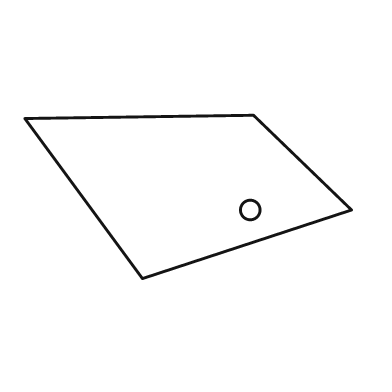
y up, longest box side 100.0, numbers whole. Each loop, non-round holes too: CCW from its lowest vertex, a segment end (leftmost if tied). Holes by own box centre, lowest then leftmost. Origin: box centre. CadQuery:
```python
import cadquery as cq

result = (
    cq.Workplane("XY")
    .moveTo(-14.0, -25.0)
    .lineTo(50.0, -4.0)
    .lineTo(20.0, 25.0)
    .lineTo(-50.0, 24.0)
    .close()
    .moveTo(19.0, -4.0)
    .circle(3.0)
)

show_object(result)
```